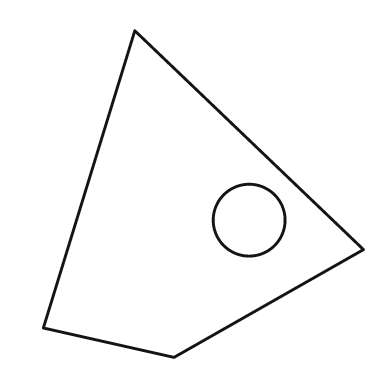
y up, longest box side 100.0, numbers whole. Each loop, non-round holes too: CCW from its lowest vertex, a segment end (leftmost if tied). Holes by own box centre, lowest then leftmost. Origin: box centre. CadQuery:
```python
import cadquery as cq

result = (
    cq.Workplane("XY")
    .moveTo(-9.0, -50.0)
    .lineTo(49.0, -17.0)
    .lineTo(-21.0, 50.0)
    .lineTo(-49.0, -41.0)
    .close()
    .moveTo(14.0, -8.0)
    .circle(11.0)
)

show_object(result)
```